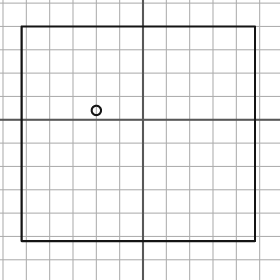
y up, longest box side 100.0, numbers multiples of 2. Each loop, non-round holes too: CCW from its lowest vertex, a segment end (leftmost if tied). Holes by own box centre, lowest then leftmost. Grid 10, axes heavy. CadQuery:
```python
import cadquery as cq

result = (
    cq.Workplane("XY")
    .moveTo(-52.0, -52.0)
    .lineTo(48.0, -52.0)
    .lineTo(48.0, 40.0)
    .lineTo(-52.0, 40.0)
    .close()
    .moveTo(-20.0, 4.0)
    .circle(2.0)
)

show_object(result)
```